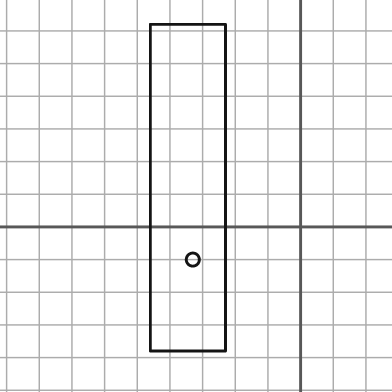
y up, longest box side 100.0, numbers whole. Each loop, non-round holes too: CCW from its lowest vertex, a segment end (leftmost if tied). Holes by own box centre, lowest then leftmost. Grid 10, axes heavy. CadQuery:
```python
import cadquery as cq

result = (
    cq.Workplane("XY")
    .moveTo(-46.0, -38.0)
    .lineTo(-23.0, -38.0)
    .lineTo(-23.0, 62.0)
    .lineTo(-46.0, 62.0)
    .close()
    .moveTo(-33.0, -10.0)
    .circle(2.0)
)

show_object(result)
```